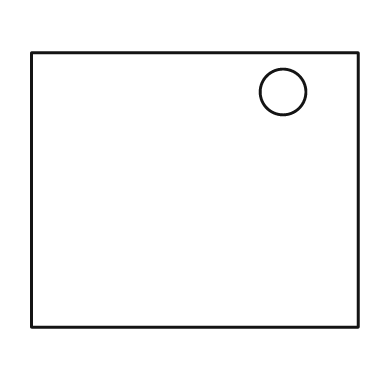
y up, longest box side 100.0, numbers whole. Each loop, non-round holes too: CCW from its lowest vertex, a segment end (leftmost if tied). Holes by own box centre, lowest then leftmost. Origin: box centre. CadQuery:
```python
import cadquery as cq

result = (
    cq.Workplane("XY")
    .moveTo(-50.0, -42.0)
    .lineTo(50.0, -42.0)
    .lineTo(50.0, 42.0)
    .lineTo(-50.0, 42.0)
    .close()
    .moveTo(27.0, 30.0)
    .circle(7.0)
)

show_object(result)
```